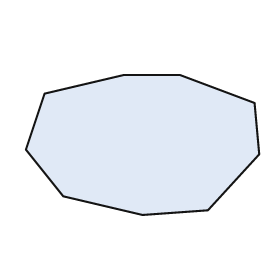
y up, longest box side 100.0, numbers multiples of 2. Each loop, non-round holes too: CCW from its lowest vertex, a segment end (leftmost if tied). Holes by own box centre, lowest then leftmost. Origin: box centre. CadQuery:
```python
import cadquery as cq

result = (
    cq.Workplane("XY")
    .moveTo(0.0, -30.0)
    .lineTo(28.0, -28.0)
    .lineTo(50.0, -4.0)
    .lineTo(48.0, 18.0)
    .lineTo(16.0, 30.0)
    .lineTo(-8.0, 30.0)
    .lineTo(-42.0, 22.0)
    .lineTo(-50.0, -2.0)
    .lineTo(-34.0, -22.0)
    .close()
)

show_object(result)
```